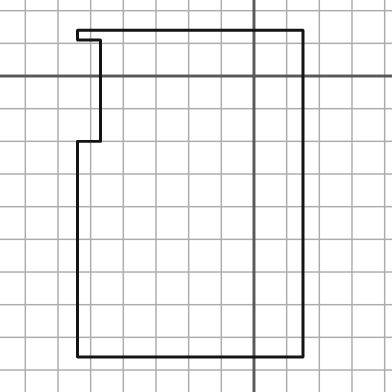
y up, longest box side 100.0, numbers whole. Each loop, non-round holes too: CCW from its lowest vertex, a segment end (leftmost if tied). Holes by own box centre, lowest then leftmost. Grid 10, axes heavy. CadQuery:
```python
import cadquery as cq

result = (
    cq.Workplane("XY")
    .moveTo(-54.0, -86.0)
    .lineTo(15.0, -86.0)
    .lineTo(15.0, 14.0)
    .lineTo(-54.0, 14.0)
    .lineTo(-54.0, 11.0)
    .lineTo(-47.0, 11.0)
    .lineTo(-47.0, -20.0)
    .lineTo(-54.0, -20.0)
    .close()
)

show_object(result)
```